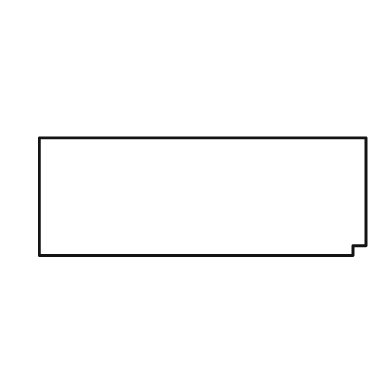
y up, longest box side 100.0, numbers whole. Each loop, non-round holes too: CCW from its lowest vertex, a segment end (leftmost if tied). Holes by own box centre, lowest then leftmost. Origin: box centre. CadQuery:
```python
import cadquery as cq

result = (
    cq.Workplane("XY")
    .moveTo(-50.0, -18.0)
    .lineTo(46.0, -18.0)
    .lineTo(46.0, -15.0)
    .lineTo(50.0, -15.0)
    .lineTo(50.0, 18.0)
    .lineTo(-50.0, 18.0)
    .close()
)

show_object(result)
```